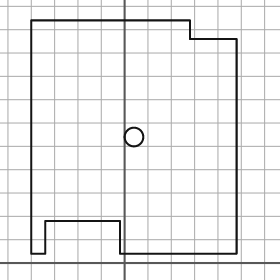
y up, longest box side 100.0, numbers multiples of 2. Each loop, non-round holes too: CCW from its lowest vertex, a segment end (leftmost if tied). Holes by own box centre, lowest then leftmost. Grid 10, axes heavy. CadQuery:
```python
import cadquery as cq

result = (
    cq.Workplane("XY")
    .moveTo(-40.0, 4.0)
    .lineTo(-34.0, 4.0)
    .lineTo(-34.0, 18.0)
    .lineTo(-2.0, 18.0)
    .lineTo(-2.0, 4.0)
    .lineTo(48.0, 4.0)
    .lineTo(48.0, 96.0)
    .lineTo(28.0, 96.0)
    .lineTo(28.0, 104.0)
    .lineTo(-40.0, 104.0)
    .close()
    .moveTo(4.0, 54.0)
    .circle(4.0)
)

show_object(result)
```